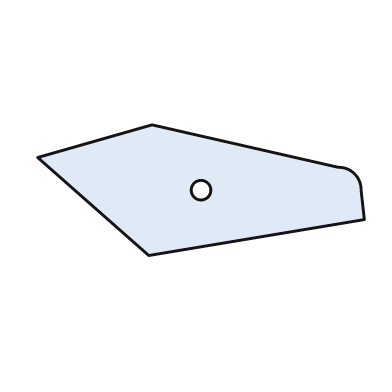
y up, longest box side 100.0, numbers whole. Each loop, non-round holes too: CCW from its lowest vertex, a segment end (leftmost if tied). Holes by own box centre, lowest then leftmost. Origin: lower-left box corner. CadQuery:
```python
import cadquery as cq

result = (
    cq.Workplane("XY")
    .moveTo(34.0, 0.0)
    .lineTo(100.0, 11.0)
    .lineTo(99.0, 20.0)
    .threePointArc((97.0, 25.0), (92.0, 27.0))
    .lineTo(35.0, 40.0)
    .lineTo(0.0, 30.0)
    .close()
    .moveTo(50.0, 20.0)
    .circle(3.0)
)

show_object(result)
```